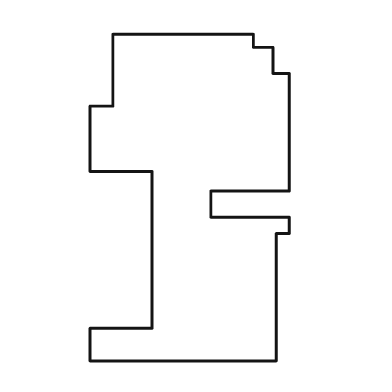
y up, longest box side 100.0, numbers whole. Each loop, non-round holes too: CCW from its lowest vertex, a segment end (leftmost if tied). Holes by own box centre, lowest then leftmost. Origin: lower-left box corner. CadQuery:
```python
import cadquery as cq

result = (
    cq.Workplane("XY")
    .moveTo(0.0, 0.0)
    .lineTo(57.0, 0.0)
    .lineTo(57.0, 39.0)
    .lineTo(61.0, 39.0)
    .lineTo(61.0, 44.0)
    .lineTo(37.0, 44.0)
    .lineTo(37.0, 52.0)
    .lineTo(61.0, 52.0)
    .lineTo(61.0, 88.0)
    .lineTo(56.0, 88.0)
    .lineTo(56.0, 96.0)
    .lineTo(50.0, 96.0)
    .lineTo(50.0, 100.0)
    .lineTo(7.0, 100.0)
    .lineTo(7.0, 78.0)
    .lineTo(0.0, 78.0)
    .lineTo(0.0, 58.0)
    .lineTo(19.0, 58.0)
    .lineTo(19.0, 10.0)
    .lineTo(0.0, 10.0)
    .close()
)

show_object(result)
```